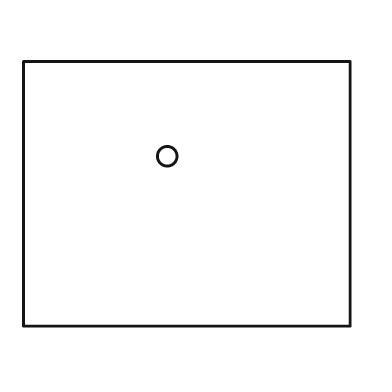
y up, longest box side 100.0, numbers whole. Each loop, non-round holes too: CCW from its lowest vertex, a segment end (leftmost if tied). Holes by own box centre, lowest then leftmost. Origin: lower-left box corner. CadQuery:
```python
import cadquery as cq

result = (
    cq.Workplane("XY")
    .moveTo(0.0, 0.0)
    .lineTo(100.0, 0.0)
    .lineTo(100.0, 81.0)
    .lineTo(0.0, 81.0)
    .close()
    .moveTo(44.0, 52.0)
    .circle(3.0)
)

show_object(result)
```